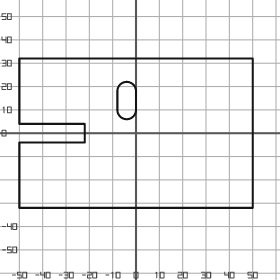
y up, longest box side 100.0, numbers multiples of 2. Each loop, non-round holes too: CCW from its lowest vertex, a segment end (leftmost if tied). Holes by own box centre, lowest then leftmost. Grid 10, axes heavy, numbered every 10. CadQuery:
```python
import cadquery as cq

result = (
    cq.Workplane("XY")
    .moveTo(-50.0, -32.0)
    .lineTo(50.0, -32.0)
    .lineTo(50.0, 32.0)
    .lineTo(-50.0, 32.0)
    .lineTo(-50.0, 4.0)
    .lineTo(-22.0, 4.0)
    .lineTo(-22.0, -4.0)
    .lineTo(-50.0, -4.0)
    .close()
    .moveTo(-8.0, 10.0)
    .threePointArc((-4.0, 6.0), (0.0, 10.0))
    .lineTo(0.0, 18.0)
    .threePointArc((-4.0, 22.0), (-8.0, 18.0))
    .close()
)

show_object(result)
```